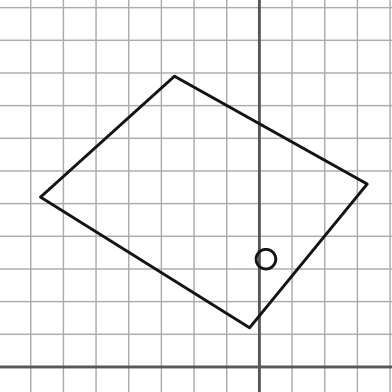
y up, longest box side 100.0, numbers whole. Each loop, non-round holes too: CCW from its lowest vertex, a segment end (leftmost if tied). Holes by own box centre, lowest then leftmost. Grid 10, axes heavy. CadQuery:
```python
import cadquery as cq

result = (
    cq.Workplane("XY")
    .moveTo(-3.0, 12.0)
    .lineTo(33.0, 56.0)
    .lineTo(-26.0, 89.0)
    .lineTo(-67.0, 52.0)
    .close()
    .moveTo(2.0, 33.0)
    .circle(3.0)
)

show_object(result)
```